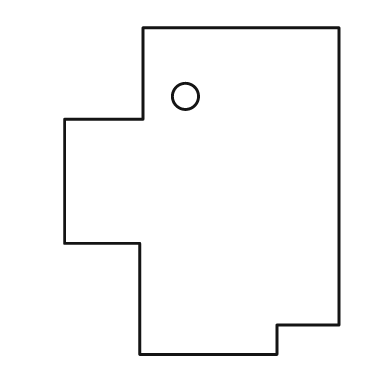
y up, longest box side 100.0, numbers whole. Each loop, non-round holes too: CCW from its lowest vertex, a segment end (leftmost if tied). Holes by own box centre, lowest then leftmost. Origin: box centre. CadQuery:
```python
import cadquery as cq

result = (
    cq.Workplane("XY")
    .moveTo(-19.0, -50.0)
    .lineTo(23.0, -50.0)
    .lineTo(23.0, -41.0)
    .lineTo(42.0, -41.0)
    .lineTo(42.0, 50.0)
    .lineTo(-18.0, 50.0)
    .lineTo(-18.0, 22.0)
    .lineTo(-42.0, 22.0)
    .lineTo(-42.0, -16.0)
    .lineTo(-19.0, -16.0)
    .close()
    .moveTo(-5.0, 29.0)
    .circle(4.0)
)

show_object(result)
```